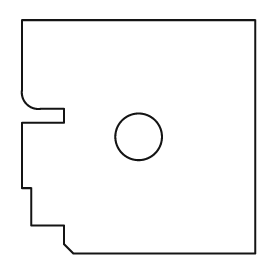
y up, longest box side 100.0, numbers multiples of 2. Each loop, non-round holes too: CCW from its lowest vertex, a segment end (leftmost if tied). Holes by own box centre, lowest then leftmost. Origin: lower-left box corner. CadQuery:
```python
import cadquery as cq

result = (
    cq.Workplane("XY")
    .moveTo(22.0, 0.0)
    .lineTo(100.0, 0.0)
    .lineTo(100.0, 100.0)
    .lineTo(0.0, 100.0)
    .lineTo(0.0, 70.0)
    .threePointArc((2.0, 64.0), (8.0, 62.0))
    .lineTo(18.0, 62.0)
    .lineTo(18.0, 56.0)
    .lineTo(0.0, 56.0)
    .lineTo(0.0, 28.0)
    .lineTo(4.0, 28.0)
    .lineTo(4.0, 12.0)
    .lineTo(18.0, 12.0)
    .lineTo(18.0, 4.0)
    .close()
    .moveTo(50.0, 50.0)
    .circle(10.0)
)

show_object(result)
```